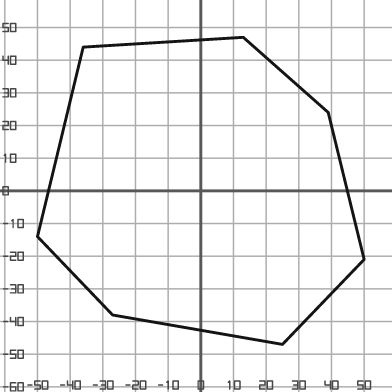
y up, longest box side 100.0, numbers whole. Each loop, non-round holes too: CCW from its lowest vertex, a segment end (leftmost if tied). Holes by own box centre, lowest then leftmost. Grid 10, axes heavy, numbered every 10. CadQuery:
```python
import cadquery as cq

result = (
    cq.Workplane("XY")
    .moveTo(25.0, -47.0)
    .lineTo(50.0, -21.0)
    .lineTo(39.0, 24.0)
    .lineTo(13.0, 47.0)
    .lineTo(-36.0, 44.0)
    .lineTo(-50.0, -14.0)
    .lineTo(-27.0, -38.0)
    .close()
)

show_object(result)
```